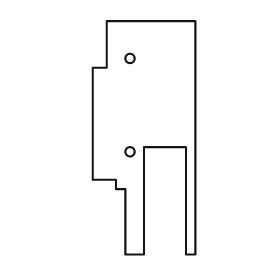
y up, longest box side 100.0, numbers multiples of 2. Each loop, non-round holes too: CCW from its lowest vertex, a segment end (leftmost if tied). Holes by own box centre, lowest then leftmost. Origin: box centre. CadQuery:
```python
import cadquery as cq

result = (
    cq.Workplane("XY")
    .moveTo(-8.0, -50.0)
    .lineTo(0.0, -50.0)
    .lineTo(0.0, -4.0)
    .lineTo(18.0, -4.0)
    .lineTo(18.0, -50.0)
    .lineTo(22.0, -50.0)
    .lineTo(22.0, 50.0)
    .lineTo(-16.0, 50.0)
    .lineTo(-16.0, 30.0)
    .lineTo(-22.0, 30.0)
    .lineTo(-22.0, -18.0)
    .lineTo(-12.0, -18.0)
    .lineTo(-12.0, -22.0)
    .lineTo(-8.0, -22.0)
    .close()
    .moveTo(-6.0, -6.0)
    .circle(2.0)
    .moveTo(-6.0, 34.0)
    .circle(2.0)
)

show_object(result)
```